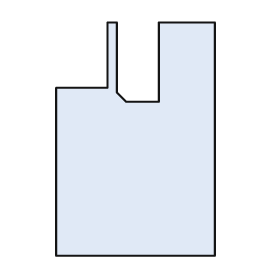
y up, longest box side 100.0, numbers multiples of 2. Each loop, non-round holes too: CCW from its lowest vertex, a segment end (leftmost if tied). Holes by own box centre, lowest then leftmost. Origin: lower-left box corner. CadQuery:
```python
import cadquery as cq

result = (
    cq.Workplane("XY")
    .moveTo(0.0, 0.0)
    .lineTo(68.0, 0.0)
    .lineTo(68.0, 100.0)
    .lineTo(44.0, 100.0)
    .lineTo(44.0, 66.0)
    .lineTo(30.0, 66.0)
    .lineTo(26.0, 70.0)
    .lineTo(26.0, 100.0)
    .lineTo(22.0, 100.0)
    .lineTo(22.0, 72.0)
    .lineTo(0.0, 72.0)
    .close()
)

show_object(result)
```